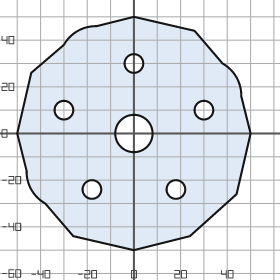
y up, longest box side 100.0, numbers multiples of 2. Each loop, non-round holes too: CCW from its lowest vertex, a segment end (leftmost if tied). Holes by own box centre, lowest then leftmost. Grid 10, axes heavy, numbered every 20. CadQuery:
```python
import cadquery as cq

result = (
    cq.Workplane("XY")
    .moveTo(0.0, -50.0)
    .lineTo(24.0, -44.0)
    .lineTo(44.0, -26.0)
    .lineTo(50.0, 0.0)
    .lineTo(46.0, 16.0)
    .threePointArc((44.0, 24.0), (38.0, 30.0))
    .lineTo(26.0, 44.0)
    .lineTo(0.0, 50.0)
    .lineTo(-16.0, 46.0)
    .threePointArc((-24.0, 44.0), (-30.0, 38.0))
    .lineTo(-44.0, 26.0)
    .lineTo(-50.0, 0.0)
    .lineTo(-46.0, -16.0)
    .threePointArc((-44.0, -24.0), (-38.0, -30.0))
    .lineTo(-26.0, -44.0)
    .close()
    .moveTo(-18.0, -24.0)
    .circle(4.0)
    .moveTo(18.0, -24.0)
    .circle(4.0)
    .moveTo(0.0, 0.0)
    .circle(8.0)
    .moveTo(-30.0, 10.0)
    .circle(4.0)
    .moveTo(30.0, 10.0)
    .circle(4.0)
    .moveTo(0.0, 30.0)
    .circle(4.0)
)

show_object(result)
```